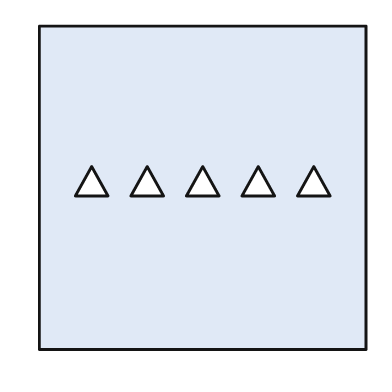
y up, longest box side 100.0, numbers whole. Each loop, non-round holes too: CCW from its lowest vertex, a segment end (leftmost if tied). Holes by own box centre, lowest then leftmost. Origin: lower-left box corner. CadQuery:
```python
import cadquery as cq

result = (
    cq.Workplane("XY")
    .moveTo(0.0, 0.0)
    .lineTo(100.0, 0.0)
    .lineTo(100.0, 99.0)
    .lineTo(0.0, 99.0)
    .close()
    .moveTo(11.0, 47.0)
    .lineTo(21.0, 47.0)
    .lineTo(16.0, 56.0)
    .close()
    .moveTo(28.0, 47.0)
    .lineTo(38.0, 47.0)
    .lineTo(33.0, 56.0)
    .close()
    .moveTo(45.0, 47.0)
    .lineTo(55.0, 47.0)
    .lineTo(50.0, 56.0)
    .close()
    .moveTo(62.0, 47.0)
    .lineTo(72.0, 47.0)
    .lineTo(67.0, 56.0)
    .close()
    .moveTo(79.0, 47.0)
    .lineTo(89.0, 47.0)
    .lineTo(84.0, 56.0)
    .close()
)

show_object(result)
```